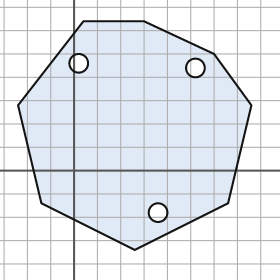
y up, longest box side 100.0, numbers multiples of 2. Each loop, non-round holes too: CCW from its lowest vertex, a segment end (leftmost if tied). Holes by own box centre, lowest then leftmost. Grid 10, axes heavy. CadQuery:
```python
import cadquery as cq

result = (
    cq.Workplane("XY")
    .moveTo(26.0, -34.0)
    .lineTo(66.0, -14.0)
    .lineTo(76.0, 28.0)
    .lineTo(60.0, 50.0)
    .lineTo(30.0, 64.0)
    .lineTo(4.0, 64.0)
    .lineTo(-24.0, 28.0)
    .lineTo(-14.0, -14.0)
    .close()
    .moveTo(36.0, -18.0)
    .circle(4.0)
    .moveTo(52.0, 44.0)
    .circle(4.0)
    .moveTo(2.0, 46.0)
    .circle(4.0)
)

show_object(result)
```